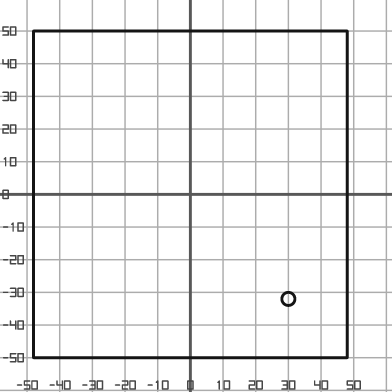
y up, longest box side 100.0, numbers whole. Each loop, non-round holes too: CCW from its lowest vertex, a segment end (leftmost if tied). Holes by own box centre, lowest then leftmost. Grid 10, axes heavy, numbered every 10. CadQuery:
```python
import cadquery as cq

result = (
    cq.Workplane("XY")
    .moveTo(-48.0, -50.0)
    .lineTo(48.0, -50.0)
    .lineTo(48.0, 50.0)
    .lineTo(-48.0, 50.0)
    .close()
    .moveTo(30.0, -32.0)
    .circle(2.0)
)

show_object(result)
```